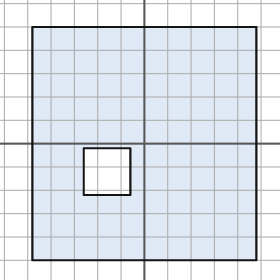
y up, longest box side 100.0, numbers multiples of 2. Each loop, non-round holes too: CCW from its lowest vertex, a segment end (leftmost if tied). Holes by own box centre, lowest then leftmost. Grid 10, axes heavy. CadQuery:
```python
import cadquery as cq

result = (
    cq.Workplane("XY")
    .moveTo(-48.0, -50.0)
    .lineTo(48.0, -50.0)
    .lineTo(48.0, 50.0)
    .lineTo(-48.0, 50.0)
    .close()
    .moveTo(-26.0, -22.0)
    .lineTo(-6.0, -22.0)
    .lineTo(-6.0, -2.0)
    .lineTo(-26.0, -2.0)
    .close()
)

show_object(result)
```